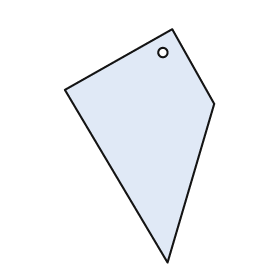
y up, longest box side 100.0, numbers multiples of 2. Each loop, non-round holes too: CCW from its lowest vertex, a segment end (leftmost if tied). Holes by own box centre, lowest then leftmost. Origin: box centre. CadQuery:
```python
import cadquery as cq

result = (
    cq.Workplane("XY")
    .moveTo(12.0, -50.0)
    .lineTo(32.0, 18.0)
    .lineTo(14.0, 50.0)
    .lineTo(-32.0, 24.0)
    .close()
    .moveTo(10.0, 40.0)
    .circle(2.0)
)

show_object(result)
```